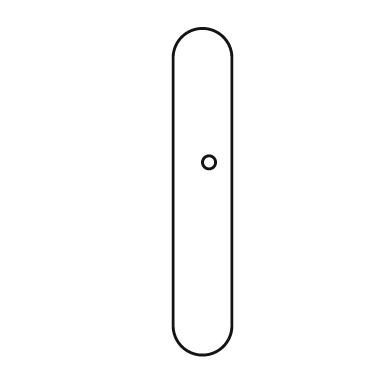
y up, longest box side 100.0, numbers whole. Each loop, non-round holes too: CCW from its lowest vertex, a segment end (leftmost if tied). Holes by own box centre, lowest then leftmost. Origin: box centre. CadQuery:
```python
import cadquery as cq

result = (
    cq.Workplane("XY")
    .moveTo(-9.0, -41.0)
    .threePointArc((0.0, -50.0), (9.0, -41.0))
    .lineTo(9.0, 41.0)
    .threePointArc((0.0, 50.0), (-9.0, 41.0))
    .close()
    .moveTo(2.0, 9.0)
    .circle(2.0)
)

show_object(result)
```